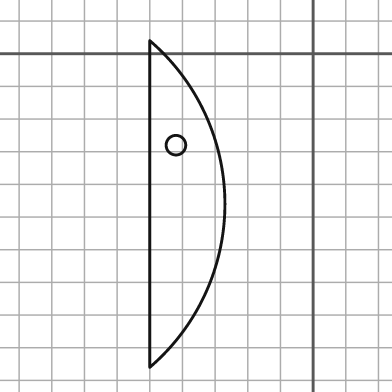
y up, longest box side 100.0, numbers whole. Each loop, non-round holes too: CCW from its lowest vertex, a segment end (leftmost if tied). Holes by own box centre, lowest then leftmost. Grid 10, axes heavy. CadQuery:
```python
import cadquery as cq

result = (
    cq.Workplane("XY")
    .moveTo(-50.0, -96.0)
    .threePointArc((-27.0, -46.0), (-50.0, 4.0))
    .close()
    .moveTo(-42.0, -28.0)
    .circle(3.0)
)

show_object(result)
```